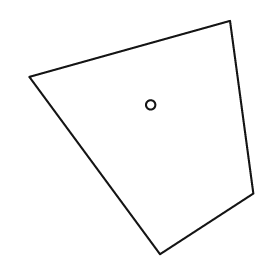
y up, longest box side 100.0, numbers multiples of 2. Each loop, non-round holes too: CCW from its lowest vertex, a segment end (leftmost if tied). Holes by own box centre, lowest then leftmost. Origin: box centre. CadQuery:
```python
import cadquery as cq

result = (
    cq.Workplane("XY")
    .moveTo(8.0, -50.0)
    .lineTo(48.0, -24.0)
    .lineTo(38.0, 50.0)
    .lineTo(-48.0, 26.0)
    .close()
    .moveTo(4.0, 14.0)
    .circle(2.0)
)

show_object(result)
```